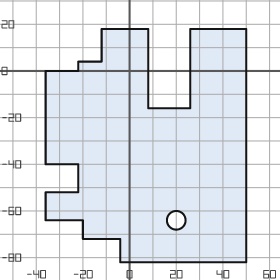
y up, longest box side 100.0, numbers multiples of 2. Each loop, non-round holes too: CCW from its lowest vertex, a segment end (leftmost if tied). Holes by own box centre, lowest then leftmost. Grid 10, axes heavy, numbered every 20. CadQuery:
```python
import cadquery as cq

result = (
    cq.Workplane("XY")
    .moveTo(-4.0, -82.0)
    .lineTo(50.0, -82.0)
    .lineTo(50.0, 18.0)
    .lineTo(26.0, 18.0)
    .lineTo(26.0, -16.0)
    .lineTo(8.0, -16.0)
    .lineTo(8.0, 18.0)
    .lineTo(-12.0, 18.0)
    .lineTo(-12.0, 4.0)
    .lineTo(-22.0, 4.0)
    .lineTo(-22.0, 0.0)
    .lineTo(-36.0, 0.0)
    .lineTo(-36.0, -40.0)
    .lineTo(-22.0, -40.0)
    .lineTo(-22.0, -52.0)
    .lineTo(-36.0, -52.0)
    .lineTo(-36.0, -64.0)
    .lineTo(-20.0, -64.0)
    .lineTo(-20.0, -72.0)
    .lineTo(-4.0, -72.0)
    .close()
    .moveTo(20.0, -64.0)
    .circle(4.0)
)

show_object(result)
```